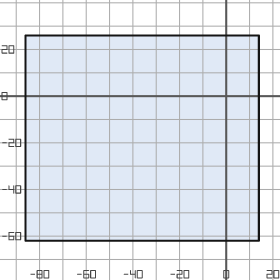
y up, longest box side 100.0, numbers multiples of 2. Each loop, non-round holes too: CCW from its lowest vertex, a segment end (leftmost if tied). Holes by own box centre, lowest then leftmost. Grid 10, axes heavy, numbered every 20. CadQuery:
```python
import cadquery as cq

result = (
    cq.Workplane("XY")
    .moveTo(-86.0, -62.0)
    .lineTo(14.0, -62.0)
    .lineTo(14.0, 26.0)
    .lineTo(-86.0, 26.0)
    .close()
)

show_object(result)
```